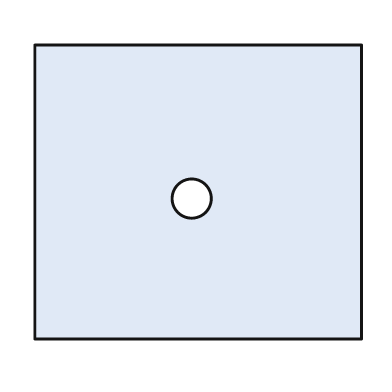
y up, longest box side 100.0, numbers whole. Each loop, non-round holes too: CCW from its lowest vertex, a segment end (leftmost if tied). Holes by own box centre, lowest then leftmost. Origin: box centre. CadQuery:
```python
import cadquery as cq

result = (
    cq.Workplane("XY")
    .moveTo(-50.0, -45.0)
    .lineTo(50.0, -45.0)
    .lineTo(50.0, 45.0)
    .lineTo(-50.0, 45.0)
    .close()
    .moveTo(-2.0, -2.0)
    .circle(6.0)
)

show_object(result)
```